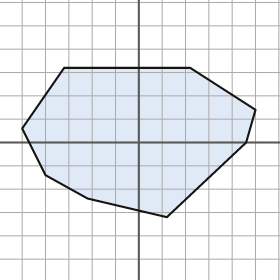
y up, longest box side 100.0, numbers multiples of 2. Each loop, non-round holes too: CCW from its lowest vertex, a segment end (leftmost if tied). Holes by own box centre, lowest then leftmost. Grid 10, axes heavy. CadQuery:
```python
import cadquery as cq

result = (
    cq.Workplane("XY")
    .moveTo(12.0, -32.0)
    .lineTo(46.0, 0.0)
    .lineTo(50.0, 14.0)
    .lineTo(22.0, 32.0)
    .lineTo(-32.0, 32.0)
    .lineTo(-50.0, 6.0)
    .lineTo(-40.0, -14.0)
    .lineTo(-22.0, -24.0)
    .close()
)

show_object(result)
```